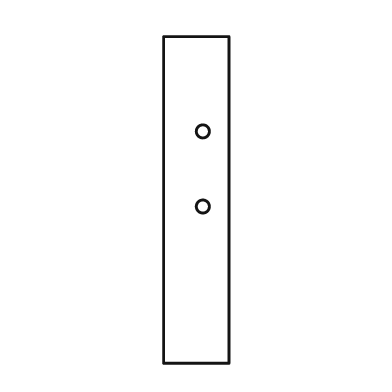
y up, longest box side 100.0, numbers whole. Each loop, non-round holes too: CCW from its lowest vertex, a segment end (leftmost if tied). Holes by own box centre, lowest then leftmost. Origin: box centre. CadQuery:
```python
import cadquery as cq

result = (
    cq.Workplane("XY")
    .moveTo(-10.0, -50.0)
    .lineTo(10.0, -50.0)
    .lineTo(10.0, 50.0)
    .lineTo(-10.0, 50.0)
    .close()
    .moveTo(2.0, -2.0)
    .circle(2.0)
    .moveTo(2.0, 21.0)
    .circle(2.0)
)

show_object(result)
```